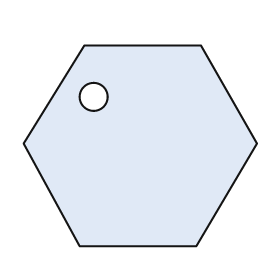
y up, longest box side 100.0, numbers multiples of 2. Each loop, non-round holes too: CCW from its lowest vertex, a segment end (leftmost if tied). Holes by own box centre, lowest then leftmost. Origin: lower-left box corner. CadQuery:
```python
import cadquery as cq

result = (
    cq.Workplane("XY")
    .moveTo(24.0, 0.0)
    .lineTo(74.0, 0.0)
    .lineTo(100.0, 44.0)
    .lineTo(76.0, 86.0)
    .lineTo(26.0, 86.0)
    .lineTo(0.0, 44.0)
    .close()
    .moveTo(30.0, 64.0)
    .circle(6.0)
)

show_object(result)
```